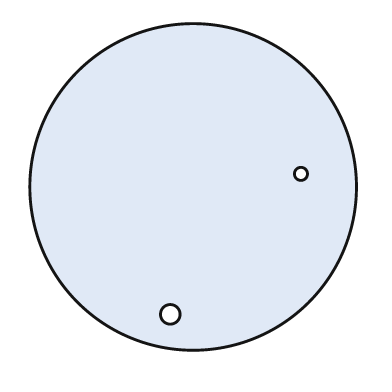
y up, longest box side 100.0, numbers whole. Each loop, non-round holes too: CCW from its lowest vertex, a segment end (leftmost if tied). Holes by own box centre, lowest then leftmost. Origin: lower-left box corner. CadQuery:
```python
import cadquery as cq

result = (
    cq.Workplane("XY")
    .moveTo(50.0, 50.0)
    .circle(50.0)
    .moveTo(43.0, 11.0)
    .circle(3.0)
    .moveTo(83.0, 54.0)
    .circle(2.0)
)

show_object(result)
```